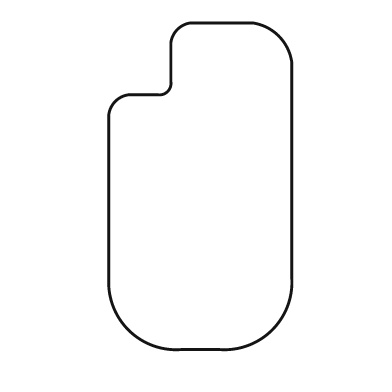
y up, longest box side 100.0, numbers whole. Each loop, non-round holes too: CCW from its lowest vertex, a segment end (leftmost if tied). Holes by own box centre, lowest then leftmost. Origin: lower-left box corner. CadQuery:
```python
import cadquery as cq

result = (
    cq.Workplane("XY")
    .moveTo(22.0, 0.0)
    .lineTo(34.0, 0.0)
    .threePointArc((50.0, 6.0), (56.0, 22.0))
    .lineTo(56.0, 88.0)
    .threePointArc((52.0, 96.0), (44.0, 100.0))
    .lineTo(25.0, 100.0)
    .threePointArc((21.0, 98.0), (19.0, 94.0))
    .lineTo(19.0, 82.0)
    .threePointArc((18.0, 79.0), (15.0, 78.0))
    .lineTo(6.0, 78.0)
    .threePointArc((2.0, 76.0), (0.0, 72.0))
    .lineTo(0.0, 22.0)
    .threePointArc((6.0, 6.0), (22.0, 0.0))
    .close()
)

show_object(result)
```